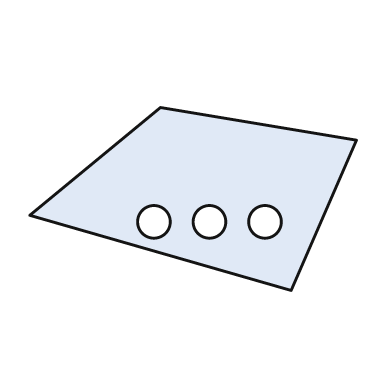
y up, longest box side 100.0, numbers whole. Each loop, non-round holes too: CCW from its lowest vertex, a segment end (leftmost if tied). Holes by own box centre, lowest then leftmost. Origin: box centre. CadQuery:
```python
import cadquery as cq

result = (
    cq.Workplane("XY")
    .moveTo(30.0, -28.0)
    .lineTo(50.0, 18.0)
    .lineTo(-10.0, 28.0)
    .lineTo(-50.0, -5.0)
    .close()
    .moveTo(-12.0, -7.0)
    .circle(5.0)
    .moveTo(5.0, -7.0)
    .circle(5.0)
    .moveTo(22.0, -7.0)
    .circle(5.0)
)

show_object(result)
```